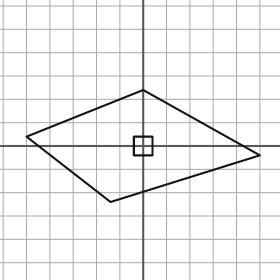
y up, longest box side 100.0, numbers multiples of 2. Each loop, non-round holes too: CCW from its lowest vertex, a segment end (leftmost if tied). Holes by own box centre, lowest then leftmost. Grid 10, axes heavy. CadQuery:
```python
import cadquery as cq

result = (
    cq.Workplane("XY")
    .moveTo(-14.0, -24.0)
    .lineTo(50.0, -4.0)
    .lineTo(0.0, 24.0)
    .lineTo(-50.0, 4.0)
    .close()
    .moveTo(-4.0, -4.0)
    .lineTo(4.0, -4.0)
    .lineTo(4.0, 4.0)
    .lineTo(-4.0, 4.0)
    .close()
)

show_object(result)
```